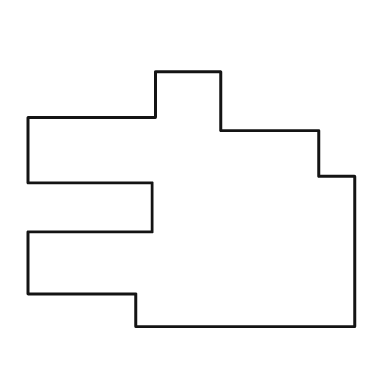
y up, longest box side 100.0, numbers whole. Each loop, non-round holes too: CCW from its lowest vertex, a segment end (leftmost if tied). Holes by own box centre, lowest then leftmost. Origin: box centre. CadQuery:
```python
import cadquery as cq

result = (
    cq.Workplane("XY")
    .moveTo(-17.0, -39.0)
    .lineTo(50.0, -39.0)
    .lineTo(50.0, 7.0)
    .lineTo(39.0, 7.0)
    .lineTo(39.0, 21.0)
    .lineTo(9.0, 21.0)
    .lineTo(9.0, 39.0)
    .lineTo(-11.0, 39.0)
    .lineTo(-11.0, 25.0)
    .lineTo(-50.0, 25.0)
    .lineTo(-50.0, 5.0)
    .lineTo(-12.0, 5.0)
    .lineTo(-12.0, -10.0)
    .lineTo(-50.0, -10.0)
    .lineTo(-50.0, -29.0)
    .lineTo(-17.0, -29.0)
    .close()
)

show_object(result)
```